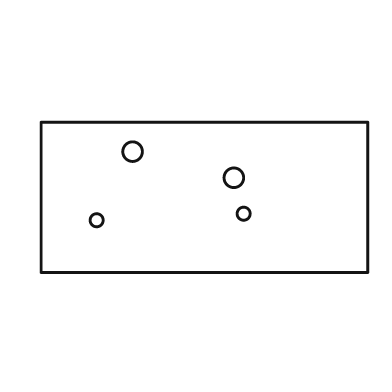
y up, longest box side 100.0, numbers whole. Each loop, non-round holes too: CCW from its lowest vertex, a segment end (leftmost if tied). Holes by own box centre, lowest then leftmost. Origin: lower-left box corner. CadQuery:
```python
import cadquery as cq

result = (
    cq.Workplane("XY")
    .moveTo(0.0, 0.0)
    .lineTo(100.0, 0.0)
    .lineTo(100.0, 46.0)
    .lineTo(0.0, 46.0)
    .close()
    .moveTo(17.0, 16.0)
    .circle(2.0)
    .moveTo(62.0, 18.0)
    .circle(2.0)
    .moveTo(59.0, 29.0)
    .circle(3.0)
    .moveTo(28.0, 37.0)
    .circle(3.0)
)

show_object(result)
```